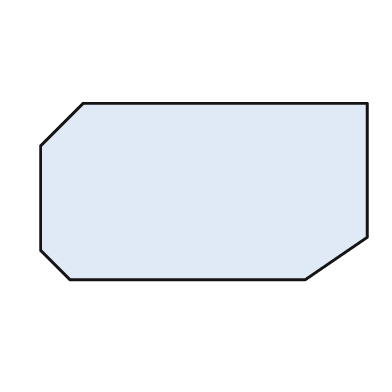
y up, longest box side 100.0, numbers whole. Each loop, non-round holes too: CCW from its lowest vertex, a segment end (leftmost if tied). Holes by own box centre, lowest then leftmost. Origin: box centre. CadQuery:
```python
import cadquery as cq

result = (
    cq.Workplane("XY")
    .moveTo(-41.0, -27.0)
    .lineTo(31.0, -27.0)
    .lineTo(50.0, -14.0)
    .lineTo(50.0, 27.0)
    .lineTo(-37.0, 27.0)
    .lineTo(-50.0, 14.0)
    .lineTo(-50.0, -18.0)
    .close()
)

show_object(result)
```